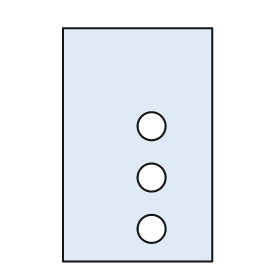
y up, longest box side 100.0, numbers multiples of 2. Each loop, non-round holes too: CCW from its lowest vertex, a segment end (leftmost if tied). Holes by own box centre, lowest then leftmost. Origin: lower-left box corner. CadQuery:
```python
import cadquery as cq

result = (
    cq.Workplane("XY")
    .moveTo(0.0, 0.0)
    .lineTo(64.0, 0.0)
    .lineTo(64.0, 100.0)
    .lineTo(0.0, 100.0)
    .close()
    .moveTo(38.0, 14.0)
    .circle(6.0)
    .moveTo(38.0, 36.0)
    .circle(6.0)
    .moveTo(38.0, 58.0)
    .circle(6.0)
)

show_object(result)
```